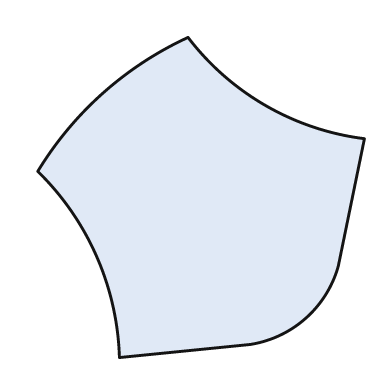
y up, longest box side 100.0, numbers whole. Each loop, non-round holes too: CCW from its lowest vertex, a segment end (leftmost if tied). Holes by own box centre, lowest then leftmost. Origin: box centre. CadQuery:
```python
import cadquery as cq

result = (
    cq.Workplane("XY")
    .moveTo(-25.0, -49.0)
    .lineTo(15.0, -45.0)
    .threePointArc((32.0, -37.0), (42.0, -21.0))
    .lineTo(50.0, 18.0)
    .threePointArc((20.0, 28.0), (-4.0, 49.0))
    .threePointArc((-30.0, 32.0), (-50.0, 8.0))
    .threePointArc((-32.0, -18.0), (-25.0, -49.0))
    .close()
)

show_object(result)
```